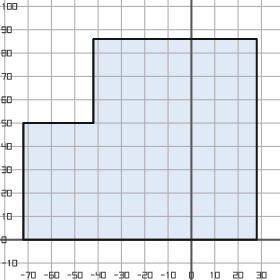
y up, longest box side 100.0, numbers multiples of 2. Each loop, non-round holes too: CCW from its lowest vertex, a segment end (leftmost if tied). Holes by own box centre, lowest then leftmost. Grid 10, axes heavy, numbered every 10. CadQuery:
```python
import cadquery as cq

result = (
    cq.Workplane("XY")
    .moveTo(-72.0, 0.0)
    .lineTo(28.0, 0.0)
    .lineTo(28.0, 86.0)
    .lineTo(-42.0, 86.0)
    .lineTo(-42.0, 50.0)
    .lineTo(-72.0, 50.0)
    .close()
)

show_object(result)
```